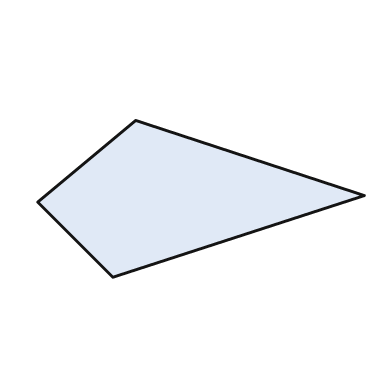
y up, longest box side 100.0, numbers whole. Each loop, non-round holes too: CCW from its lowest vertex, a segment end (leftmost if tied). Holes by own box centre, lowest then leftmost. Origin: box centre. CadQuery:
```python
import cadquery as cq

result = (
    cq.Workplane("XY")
    .moveTo(-27.0, -24.0)
    .lineTo(50.0, 1.0)
    .lineTo(-20.0, 24.0)
    .lineTo(-50.0, -1.0)
    .close()
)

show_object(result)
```